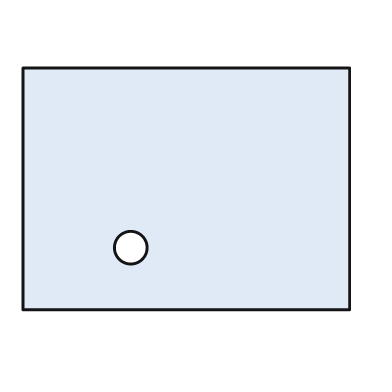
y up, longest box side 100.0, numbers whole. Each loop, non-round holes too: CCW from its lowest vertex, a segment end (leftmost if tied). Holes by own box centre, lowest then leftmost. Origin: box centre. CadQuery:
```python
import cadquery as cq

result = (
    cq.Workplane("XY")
    .moveTo(-50.0, -37.0)
    .lineTo(50.0, -37.0)
    .lineTo(50.0, 37.0)
    .lineTo(-50.0, 37.0)
    .close()
    .moveTo(-17.0, -18.0)
    .circle(5.0)
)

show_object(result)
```